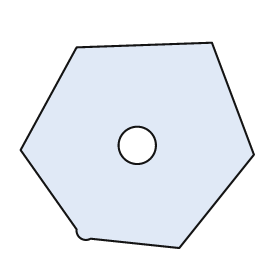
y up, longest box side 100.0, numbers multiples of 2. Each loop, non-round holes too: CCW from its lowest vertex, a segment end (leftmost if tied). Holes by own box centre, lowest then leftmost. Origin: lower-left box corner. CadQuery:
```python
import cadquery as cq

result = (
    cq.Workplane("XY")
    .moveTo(68.0, 0.0)
    .lineTo(100.0, 40.0)
    .lineTo(82.0, 88.0)
    .lineTo(24.0, 86.0)
    .lineTo(0.0, 42.0)
    .lineTo(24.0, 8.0)
    .threePointArc((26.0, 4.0), (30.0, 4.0))
    .close()
    .moveTo(50.0, 44.0)
    .circle(8.0)
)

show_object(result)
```